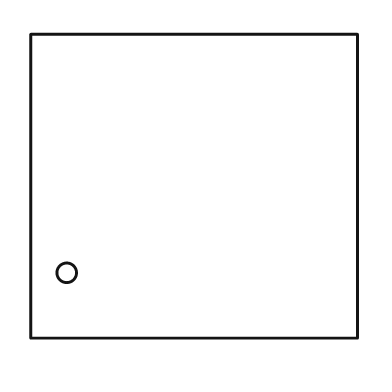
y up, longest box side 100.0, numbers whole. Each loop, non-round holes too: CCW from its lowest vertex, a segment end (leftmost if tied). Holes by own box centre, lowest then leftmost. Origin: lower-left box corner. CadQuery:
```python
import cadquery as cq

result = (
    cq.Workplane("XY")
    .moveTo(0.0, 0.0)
    .lineTo(100.0, 0.0)
    .lineTo(100.0, 93.0)
    .lineTo(0.0, 93.0)
    .close()
    .moveTo(11.0, 20.0)
    .circle(3.0)
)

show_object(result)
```